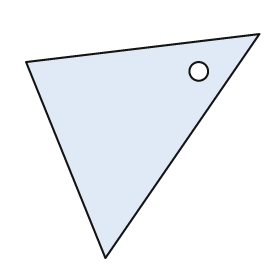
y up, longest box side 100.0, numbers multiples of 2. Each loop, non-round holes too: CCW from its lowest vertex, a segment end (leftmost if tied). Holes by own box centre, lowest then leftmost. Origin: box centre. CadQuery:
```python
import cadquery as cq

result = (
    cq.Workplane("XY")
    .moveTo(-16.0, -48.0)
    .lineTo(50.0, 48.0)
    .lineTo(-50.0, 36.0)
    .close()
    .moveTo(24.0, 32.0)
    .circle(4.0)
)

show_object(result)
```